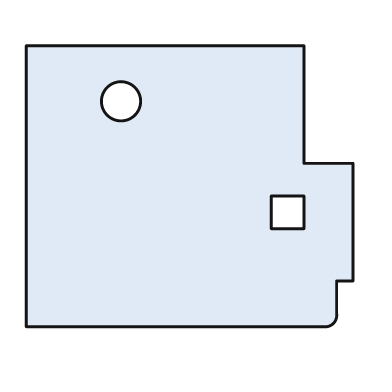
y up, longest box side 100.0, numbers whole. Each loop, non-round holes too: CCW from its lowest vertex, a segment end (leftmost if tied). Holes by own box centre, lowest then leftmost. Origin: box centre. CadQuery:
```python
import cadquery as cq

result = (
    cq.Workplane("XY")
    .moveTo(-50.0, -43.0)
    .lineTo(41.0, -43.0)
    .threePointArc((44.0, -42.0), (45.0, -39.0))
    .lineTo(45.0, -29.0)
    .lineTo(50.0, -29.0)
    .lineTo(50.0, 7.0)
    .lineTo(35.0, 7.0)
    .lineTo(35.0, 43.0)
    .lineTo(-50.0, 43.0)
    .close()
    .moveTo(25.0, -13.0)
    .lineTo(35.0, -13.0)
    .lineTo(35.0, -3.0)
    .lineTo(25.0, -3.0)
    .close()
    .moveTo(-21.0, 26.0)
    .circle(6.0)
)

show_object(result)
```